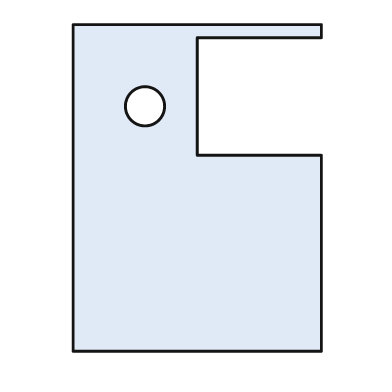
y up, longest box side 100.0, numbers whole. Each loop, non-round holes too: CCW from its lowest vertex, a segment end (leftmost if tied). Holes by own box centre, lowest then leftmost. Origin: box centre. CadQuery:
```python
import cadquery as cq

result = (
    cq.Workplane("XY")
    .moveTo(-38.0, -50.0)
    .lineTo(38.0, -50.0)
    .lineTo(38.0, 10.0)
    .lineTo(0.0, 10.0)
    .lineTo(0.0, 46.0)
    .lineTo(38.0, 46.0)
    .lineTo(38.0, 50.0)
    .lineTo(-38.0, 50.0)
    .close()
    .moveTo(-16.0, 25.0)
    .circle(6.0)
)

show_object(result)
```